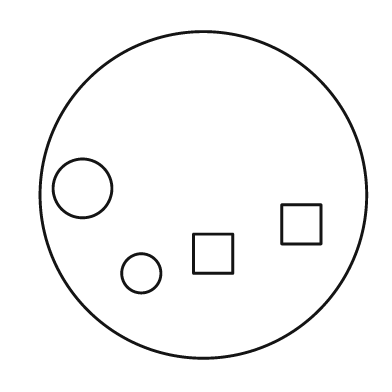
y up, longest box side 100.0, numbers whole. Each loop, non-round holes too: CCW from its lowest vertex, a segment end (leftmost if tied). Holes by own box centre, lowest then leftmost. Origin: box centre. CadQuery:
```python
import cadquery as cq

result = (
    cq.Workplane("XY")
    .moveTo(0.0, 0.0)
    .circle(50.0)
    .moveTo(-19.0, -24.0)
    .circle(6.0)
    .moveTo(-3.0, -24.0)
    .lineTo(9.0, -24.0)
    .lineTo(9.0, -12.0)
    .lineTo(-3.0, -12.0)
    .close()
    .moveTo(24.0, -15.0)
    .lineTo(36.0, -15.0)
    .lineTo(36.0, -3.0)
    .lineTo(24.0, -3.0)
    .close()
    .moveTo(-37.0, 2.0)
    .circle(9.0)
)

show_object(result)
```